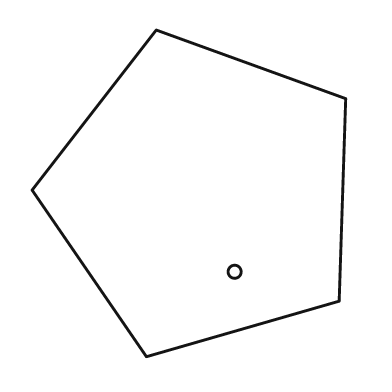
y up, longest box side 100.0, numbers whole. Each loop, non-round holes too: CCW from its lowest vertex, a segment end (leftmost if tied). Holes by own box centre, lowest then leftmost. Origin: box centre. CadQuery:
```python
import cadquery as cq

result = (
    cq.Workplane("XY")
    .moveTo(-13.0, -50.0)
    .lineTo(46.0, -33.0)
    .lineTo(48.0, 29.0)
    .lineTo(-10.0, 50.0)
    .lineTo(-48.0, 1.0)
    .close()
    .moveTo(14.0, -24.0)
    .circle(2.0)
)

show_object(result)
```